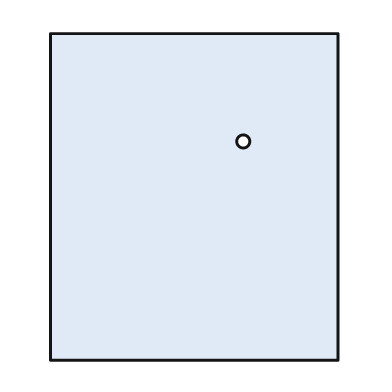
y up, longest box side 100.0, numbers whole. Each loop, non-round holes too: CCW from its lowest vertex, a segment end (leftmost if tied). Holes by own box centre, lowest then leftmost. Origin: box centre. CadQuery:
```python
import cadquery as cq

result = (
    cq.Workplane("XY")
    .moveTo(-44.0, -50.0)
    .lineTo(44.0, -50.0)
    .lineTo(44.0, 50.0)
    .lineTo(-44.0, 50.0)
    .close()
    .moveTo(15.0, 17.0)
    .circle(2.0)
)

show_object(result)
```